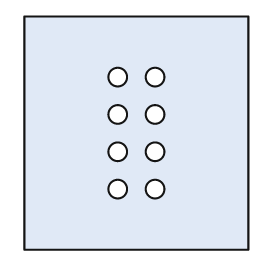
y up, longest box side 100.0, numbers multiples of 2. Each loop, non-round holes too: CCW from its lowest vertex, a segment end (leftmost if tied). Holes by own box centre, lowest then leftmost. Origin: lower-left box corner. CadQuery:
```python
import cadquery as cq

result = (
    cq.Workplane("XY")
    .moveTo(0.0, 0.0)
    .lineTo(96.0, 0.0)
    .lineTo(96.0, 100.0)
    .lineTo(0.0, 100.0)
    .close()
    .moveTo(40.0, 26.0)
    .circle(4.0)
    .moveTo(56.0, 26.0)
    .circle(4.0)
    .moveTo(40.0, 42.0)
    .circle(4.0)
    .moveTo(56.0, 42.0)
    .circle(4.0)
    .moveTo(40.0, 58.0)
    .circle(4.0)
    .moveTo(56.0, 58.0)
    .circle(4.0)
    .moveTo(40.0, 74.0)
    .circle(4.0)
    .moveTo(56.0, 74.0)
    .circle(4.0)
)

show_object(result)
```